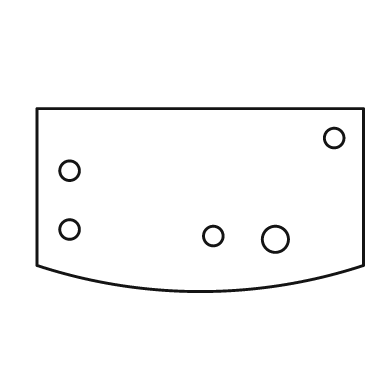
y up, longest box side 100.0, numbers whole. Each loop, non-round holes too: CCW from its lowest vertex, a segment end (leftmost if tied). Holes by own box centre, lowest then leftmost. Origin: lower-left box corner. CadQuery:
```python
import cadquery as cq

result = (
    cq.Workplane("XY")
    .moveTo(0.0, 8.0)
    .threePointArc((50.0, 0.0), (100.0, 8.0))
    .lineTo(100.0, 56.0)
    .lineTo(0.0, 56.0)
    .close()
    .moveTo(73.0, 16.0)
    .circle(4.0)
    .moveTo(54.0, 17.0)
    .circle(3.0)
    .moveTo(10.0, 19.0)
    .circle(3.0)
    .moveTo(10.0, 37.0)
    .circle(3.0)
    .moveTo(91.0, 47.0)
    .circle(3.0)
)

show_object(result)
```